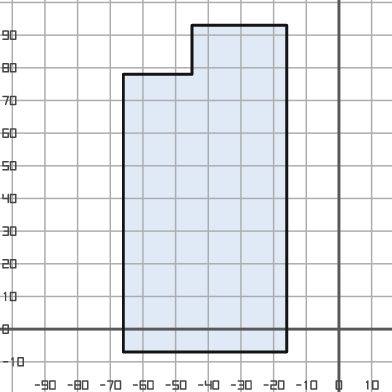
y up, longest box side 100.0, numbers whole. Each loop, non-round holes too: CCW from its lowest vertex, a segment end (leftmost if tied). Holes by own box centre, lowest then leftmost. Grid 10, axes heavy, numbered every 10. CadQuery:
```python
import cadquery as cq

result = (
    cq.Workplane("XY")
    .moveTo(-66.0, -7.0)
    .lineTo(-16.0, -7.0)
    .lineTo(-16.0, 93.0)
    .lineTo(-45.0, 93.0)
    .lineTo(-45.0, 78.0)
    .lineTo(-66.0, 78.0)
    .close()
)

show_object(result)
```